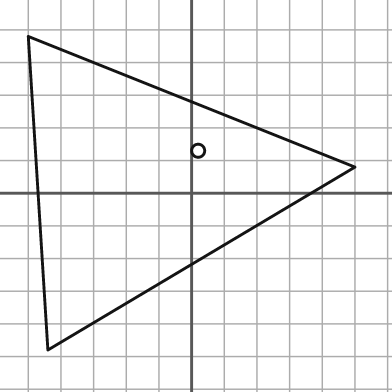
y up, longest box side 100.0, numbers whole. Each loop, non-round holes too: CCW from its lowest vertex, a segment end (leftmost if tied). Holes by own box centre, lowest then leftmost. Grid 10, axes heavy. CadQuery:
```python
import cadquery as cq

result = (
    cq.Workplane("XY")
    .moveTo(-44.0, -48.0)
    .lineTo(50.0, 8.0)
    .lineTo(-50.0, 48.0)
    .close()
    .moveTo(2.0, 13.0)
    .circle(2.0)
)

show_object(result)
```